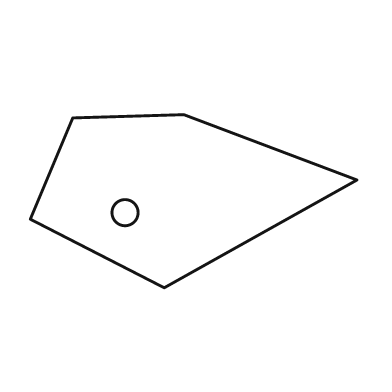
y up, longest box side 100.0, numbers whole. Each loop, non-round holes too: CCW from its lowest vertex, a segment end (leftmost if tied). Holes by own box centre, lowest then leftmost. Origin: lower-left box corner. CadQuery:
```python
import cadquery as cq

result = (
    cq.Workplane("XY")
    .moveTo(41.0, 0.0)
    .lineTo(100.0, 33.0)
    .lineTo(47.0, 53.0)
    .lineTo(13.0, 52.0)
    .lineTo(0.0, 21.0)
    .close()
    .moveTo(29.0, 23.0)
    .circle(4.0)
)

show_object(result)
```